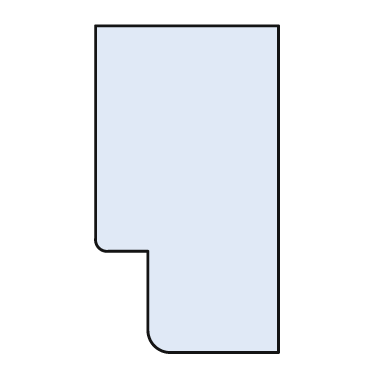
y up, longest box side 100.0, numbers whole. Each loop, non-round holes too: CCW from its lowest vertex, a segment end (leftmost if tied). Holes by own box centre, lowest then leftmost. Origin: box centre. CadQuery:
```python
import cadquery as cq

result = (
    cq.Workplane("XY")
    .moveTo(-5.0, -50.0)
    .lineTo(28.0, -50.0)
    .lineTo(28.0, 50.0)
    .lineTo(-28.0, 50.0)
    .lineTo(-28.0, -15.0)
    .threePointArc((-27.0, -18.0), (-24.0, -19.0))
    .lineTo(-12.0, -19.0)
    .lineTo(-12.0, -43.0)
    .threePointArc((-10.0, -48.0), (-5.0, -50.0))
    .close()
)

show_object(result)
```